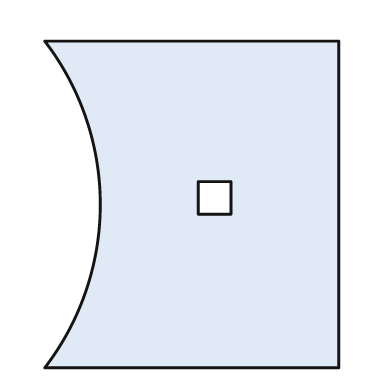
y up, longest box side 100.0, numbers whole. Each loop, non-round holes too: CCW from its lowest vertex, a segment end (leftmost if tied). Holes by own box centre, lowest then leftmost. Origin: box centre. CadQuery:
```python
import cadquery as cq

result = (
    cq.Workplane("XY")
    .moveTo(-45.0, -50.0)
    .lineTo(45.0, -50.0)
    .lineTo(45.0, 50.0)
    .lineTo(-45.0, 50.0)
    .threePointArc((-28.0, 0.0), (-45.0, -50.0))
    .close()
    .moveTo(2.0, -3.0)
    .lineTo(12.0, -3.0)
    .lineTo(12.0, 7.0)
    .lineTo(2.0, 7.0)
    .close()
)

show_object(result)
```